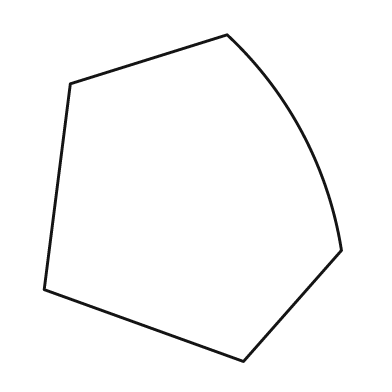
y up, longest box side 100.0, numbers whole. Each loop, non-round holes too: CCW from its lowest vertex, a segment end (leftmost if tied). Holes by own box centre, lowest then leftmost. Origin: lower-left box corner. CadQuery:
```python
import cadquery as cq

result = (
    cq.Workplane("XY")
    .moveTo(61.0, 0.0)
    .lineTo(91.0, 34.0)
    .threePointArc((79.0, 70.0), (56.0, 100.0))
    .lineTo(8.0, 85.0)
    .lineTo(0.0, 22.0)
    .close()
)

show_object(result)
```